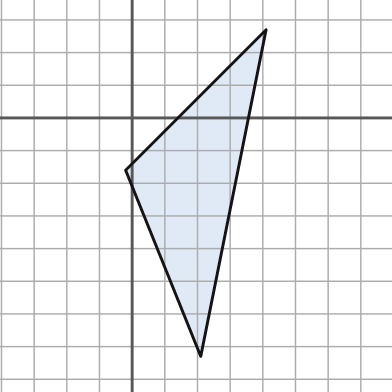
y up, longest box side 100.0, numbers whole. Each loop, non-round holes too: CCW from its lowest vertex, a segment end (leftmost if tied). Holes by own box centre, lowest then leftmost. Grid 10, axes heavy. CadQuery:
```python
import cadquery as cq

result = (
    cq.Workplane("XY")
    .moveTo(21.0, -73.0)
    .lineTo(41.0, 27.0)
    .lineTo(-2.0, -16.0)
    .close()
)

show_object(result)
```